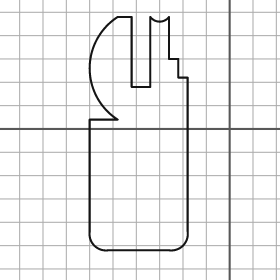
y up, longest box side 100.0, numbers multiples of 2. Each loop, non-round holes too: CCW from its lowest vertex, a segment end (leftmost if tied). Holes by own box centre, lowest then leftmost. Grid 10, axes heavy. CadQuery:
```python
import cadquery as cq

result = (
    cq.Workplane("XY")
    .moveTo(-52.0, -52.0)
    .lineTo(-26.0, -52.0)
    .threePointArc((-20.0, -50.0), (-18.0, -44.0))
    .lineTo(-18.0, 22.0)
    .lineTo(-22.0, 22.0)
    .lineTo(-22.0, 30.0)
    .lineTo(-26.0, 30.0)
    .lineTo(-26.0, 48.0)
    .threePointArc((-30.0, 46.0), (-34.0, 48.0))
    .lineTo(-34.0, 18.0)
    .lineTo(-42.0, 18.0)
    .lineTo(-42.0, 48.0)
    .lineTo(-48.0, 48.0)
    .threePointArc((-60.0, 26.0), (-48.0, 4.0))
    .lineTo(-60.0, 4.0)
    .lineTo(-60.0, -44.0)
    .threePointArc((-58.0, -50.0), (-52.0, -52.0))
    .close()
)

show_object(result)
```